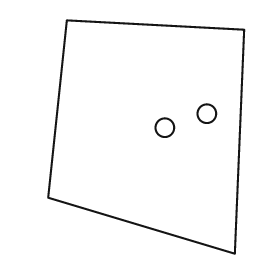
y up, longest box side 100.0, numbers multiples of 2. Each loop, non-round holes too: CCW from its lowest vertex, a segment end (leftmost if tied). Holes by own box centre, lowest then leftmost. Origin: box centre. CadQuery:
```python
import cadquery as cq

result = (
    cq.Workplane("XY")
    .moveTo(38.0, -50.0)
    .lineTo(42.0, 46.0)
    .lineTo(-34.0, 50.0)
    .lineTo(-42.0, -26.0)
    .close()
    .moveTo(8.0, 4.0)
    .circle(4.0)
    .moveTo(26.0, 10.0)
    .circle(4.0)
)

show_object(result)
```